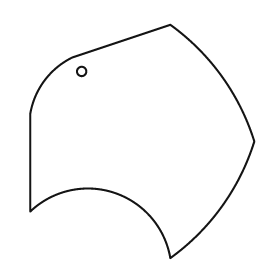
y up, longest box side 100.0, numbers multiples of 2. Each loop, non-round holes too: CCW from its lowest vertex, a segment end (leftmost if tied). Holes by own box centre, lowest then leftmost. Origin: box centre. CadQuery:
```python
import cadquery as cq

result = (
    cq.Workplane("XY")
    .moveTo(12.0, -50.0)
    .threePointArc((34.0, -28.0), (48.0, 0.0))
    .threePointArc((34.0, 28.0), (12.0, 50.0))
    .lineTo(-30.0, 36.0)
    .threePointArc((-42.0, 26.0), (-48.0, 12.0))
    .lineTo(-48.0, -30.0)
    .threePointArc((-12.0, -22.0), (12.0, -50.0))
    .close()
    .moveTo(-26.0, 30.0)
    .circle(2.0)
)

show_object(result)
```